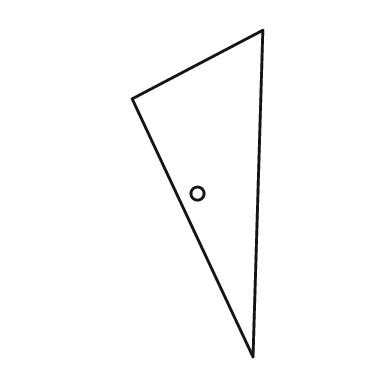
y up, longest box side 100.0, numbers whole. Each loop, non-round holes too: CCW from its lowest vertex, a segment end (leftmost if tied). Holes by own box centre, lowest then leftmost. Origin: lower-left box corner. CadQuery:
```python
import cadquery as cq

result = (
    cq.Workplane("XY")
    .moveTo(37.0, 0.0)
    .lineTo(40.0, 100.0)
    .lineTo(0.0, 79.0)
    .close()
    .moveTo(20.0, 50.0)
    .circle(2.0)
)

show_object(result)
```